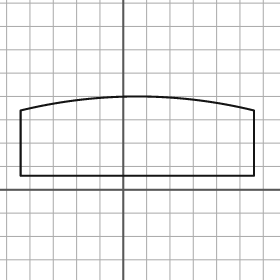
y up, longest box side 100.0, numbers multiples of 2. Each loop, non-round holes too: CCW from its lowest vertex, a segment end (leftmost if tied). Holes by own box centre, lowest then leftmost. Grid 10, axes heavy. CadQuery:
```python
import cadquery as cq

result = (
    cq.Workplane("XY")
    .moveTo(-44.0, 6.0)
    .lineTo(56.0, 6.0)
    .lineTo(56.0, 34.0)
    .threePointArc((6.0, 40.0), (-44.0, 34.0))
    .close()
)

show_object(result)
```